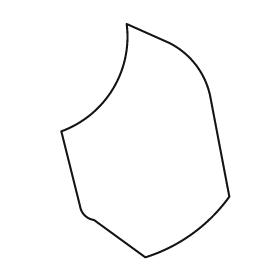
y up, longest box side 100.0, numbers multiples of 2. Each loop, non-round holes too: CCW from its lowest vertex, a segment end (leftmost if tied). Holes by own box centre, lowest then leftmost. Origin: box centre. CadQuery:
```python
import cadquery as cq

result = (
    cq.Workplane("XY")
    .moveTo(0.0, -50.0)
    .threePointArc((20.0, -40.0), (36.0, -24.0))
    .lineTo(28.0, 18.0)
    .threePointArc((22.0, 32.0), (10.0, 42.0))
    .lineTo(-8.0, 50.0)
    .threePointArc((-14.0, 22.0), (-36.0, 4.0))
    .lineTo(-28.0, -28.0)
    .threePointArc((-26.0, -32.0), (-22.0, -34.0))
    .close()
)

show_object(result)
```